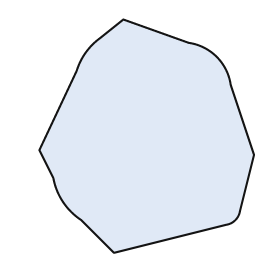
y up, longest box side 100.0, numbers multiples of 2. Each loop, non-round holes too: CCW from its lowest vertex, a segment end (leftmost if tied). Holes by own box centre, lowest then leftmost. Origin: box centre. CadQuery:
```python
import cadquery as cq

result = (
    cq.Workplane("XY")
    .moveTo(-14.0, -50.0)
    .lineTo(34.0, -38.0)
    .threePointArc((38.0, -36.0), (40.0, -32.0))
    .lineTo(46.0, -8.0)
    .lineTo(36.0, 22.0)
    .threePointArc((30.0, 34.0), (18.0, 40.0))
    .lineTo(-10.0, 50.0)
    .lineTo(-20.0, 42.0)
    .threePointArc((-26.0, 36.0), (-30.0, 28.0))
    .lineTo(-46.0, -6.0)
    .lineTo(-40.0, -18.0)
    .threePointArc((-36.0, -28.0), (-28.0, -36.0))
    .close()
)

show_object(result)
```